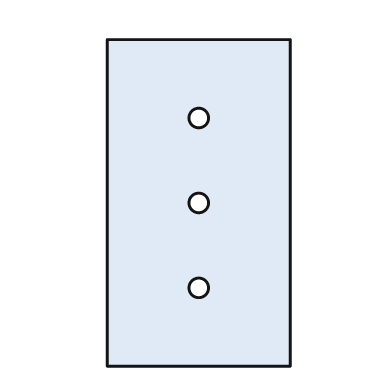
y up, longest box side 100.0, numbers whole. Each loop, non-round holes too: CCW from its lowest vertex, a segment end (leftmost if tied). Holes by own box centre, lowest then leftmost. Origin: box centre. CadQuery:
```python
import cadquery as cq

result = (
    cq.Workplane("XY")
    .moveTo(-28.0, -50.0)
    .lineTo(28.0, -50.0)
    .lineTo(28.0, 50.0)
    .lineTo(-28.0, 50.0)
    .close()
    .moveTo(0.0, -26.0)
    .circle(3.0)
    .moveTo(0.0, 0.0)
    .circle(3.0)
    .moveTo(0.0, 26.0)
    .circle(3.0)
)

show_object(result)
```